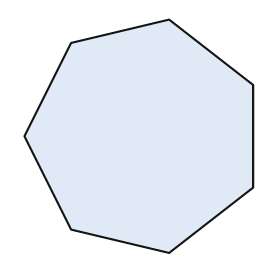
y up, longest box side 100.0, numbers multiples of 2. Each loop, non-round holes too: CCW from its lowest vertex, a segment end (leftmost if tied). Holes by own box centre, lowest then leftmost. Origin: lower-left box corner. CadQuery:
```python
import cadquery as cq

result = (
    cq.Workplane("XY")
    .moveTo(62.0, 0.0)
    .lineTo(98.0, 28.0)
    .lineTo(98.0, 72.0)
    .lineTo(62.0, 100.0)
    .lineTo(20.0, 90.0)
    .lineTo(0.0, 50.0)
    .lineTo(20.0, 10.0)
    .close()
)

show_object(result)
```